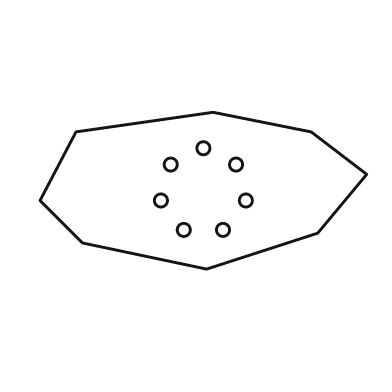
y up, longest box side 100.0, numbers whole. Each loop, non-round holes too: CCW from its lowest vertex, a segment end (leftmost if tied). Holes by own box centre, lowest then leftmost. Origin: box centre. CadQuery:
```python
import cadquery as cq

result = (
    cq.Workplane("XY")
    .moveTo(1.0, -24.0)
    .lineTo(35.0, -13.0)
    .lineTo(50.0, 5.0)
    .lineTo(33.0, 18.0)
    .lineTo(3.0, 24.0)
    .lineTo(-39.0, 18.0)
    .lineTo(-50.0, -3.0)
    .lineTo(-37.0, -16.0)
    .close()
    .moveTo(-6.0, -12.0)
    .circle(2.0)
    .moveTo(6.0, -12.0)
    .circle(2.0)
    .moveTo(-13.0, -3.0)
    .circle(2.0)
    .moveTo(13.0, -3.0)
    .circle(2.0)
    .moveTo(-10.0, 8.0)
    .circle(2.0)
    .moveTo(10.0, 8.0)
    .circle(2.0)
    .moveTo(0.0, 13.0)
    .circle(2.0)
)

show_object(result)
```